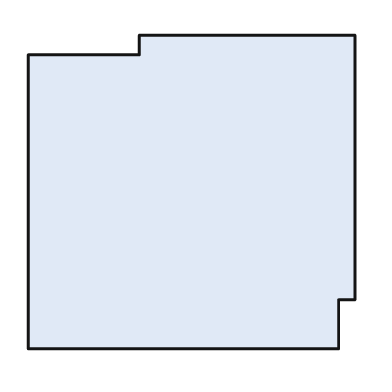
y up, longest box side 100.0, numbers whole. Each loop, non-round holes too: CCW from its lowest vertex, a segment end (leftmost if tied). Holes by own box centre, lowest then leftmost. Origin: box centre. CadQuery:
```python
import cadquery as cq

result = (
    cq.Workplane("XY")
    .moveTo(-50.0, -48.0)
    .lineTo(45.0, -48.0)
    .lineTo(45.0, -33.0)
    .lineTo(50.0, -33.0)
    .lineTo(50.0, 48.0)
    .lineTo(-16.0, 48.0)
    .lineTo(-16.0, 42.0)
    .lineTo(-50.0, 42.0)
    .close()
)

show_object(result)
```